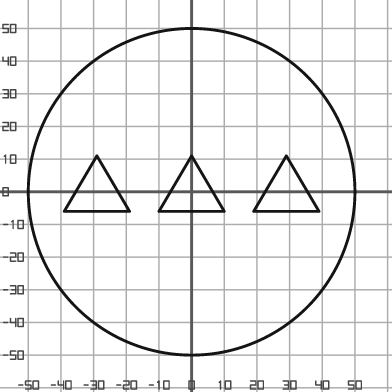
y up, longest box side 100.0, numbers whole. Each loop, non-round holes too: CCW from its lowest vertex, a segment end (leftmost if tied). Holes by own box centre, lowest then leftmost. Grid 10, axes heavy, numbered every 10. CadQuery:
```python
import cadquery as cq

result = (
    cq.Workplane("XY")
    .moveTo(0.0, 0.0)
    .circle(50.0)
    .moveTo(-39.0, -6.0)
    .lineTo(-19.0, -6.0)
    .lineTo(-29.0, 11.0)
    .close()
    .moveTo(-10.0, -6.0)
    .lineTo(10.0, -6.0)
    .lineTo(0.0, 11.0)
    .close()
    .moveTo(19.0, -6.0)
    .lineTo(39.0, -6.0)
    .lineTo(29.0, 11.0)
    .close()
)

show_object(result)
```